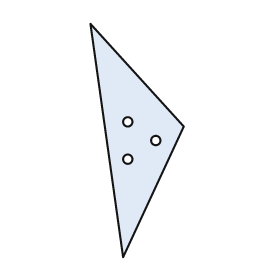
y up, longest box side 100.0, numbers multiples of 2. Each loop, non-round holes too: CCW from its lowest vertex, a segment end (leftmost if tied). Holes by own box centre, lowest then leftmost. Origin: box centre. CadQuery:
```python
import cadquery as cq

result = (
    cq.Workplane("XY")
    .moveTo(-6.0, -50.0)
    .lineTo(20.0, 6.0)
    .lineTo(-20.0, 50.0)
    .close()
    .moveTo(-4.0, -8.0)
    .circle(2.0)
    .moveTo(8.0, 0.0)
    .circle(2.0)
    .moveTo(-4.0, 8.0)
    .circle(2.0)
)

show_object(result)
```